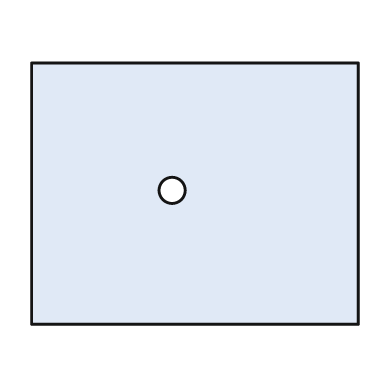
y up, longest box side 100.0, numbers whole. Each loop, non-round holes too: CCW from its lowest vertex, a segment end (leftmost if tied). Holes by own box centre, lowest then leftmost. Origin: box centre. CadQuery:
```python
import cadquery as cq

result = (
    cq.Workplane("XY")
    .moveTo(-50.0, -40.0)
    .lineTo(50.0, -40.0)
    .lineTo(50.0, 40.0)
    .lineTo(-50.0, 40.0)
    .close()
    .moveTo(-7.0, 1.0)
    .circle(4.0)
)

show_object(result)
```